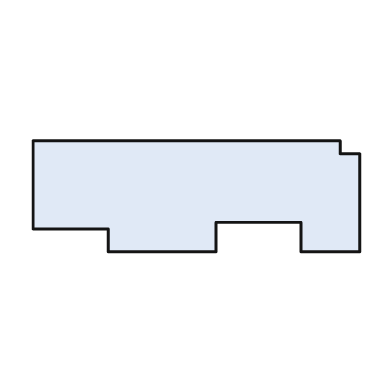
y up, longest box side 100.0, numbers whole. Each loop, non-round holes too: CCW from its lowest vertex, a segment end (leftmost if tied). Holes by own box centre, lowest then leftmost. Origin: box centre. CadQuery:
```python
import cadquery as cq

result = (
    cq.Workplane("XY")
    .moveTo(-27.0, -17.0)
    .lineTo(6.0, -17.0)
    .lineTo(6.0, -8.0)
    .lineTo(32.0, -8.0)
    .lineTo(32.0, -17.0)
    .lineTo(50.0, -17.0)
    .lineTo(50.0, 13.0)
    .lineTo(44.0, 13.0)
    .lineTo(44.0, 17.0)
    .lineTo(-50.0, 17.0)
    .lineTo(-50.0, -10.0)
    .lineTo(-27.0, -10.0)
    .close()
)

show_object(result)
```